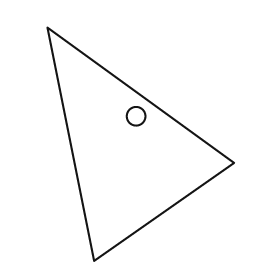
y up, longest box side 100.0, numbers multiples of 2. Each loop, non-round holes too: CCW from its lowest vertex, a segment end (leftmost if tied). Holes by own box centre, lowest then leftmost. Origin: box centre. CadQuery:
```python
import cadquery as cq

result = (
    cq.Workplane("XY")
    .moveTo(-20.0, -50.0)
    .lineTo(40.0, -8.0)
    .lineTo(-40.0, 50.0)
    .close()
    .moveTo(-2.0, 12.0)
    .circle(4.0)
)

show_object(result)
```